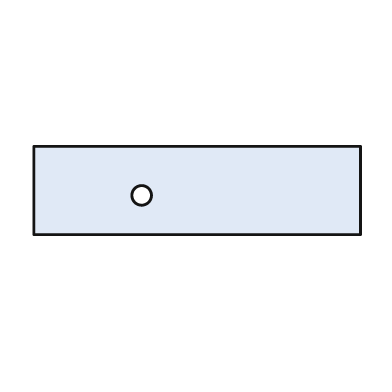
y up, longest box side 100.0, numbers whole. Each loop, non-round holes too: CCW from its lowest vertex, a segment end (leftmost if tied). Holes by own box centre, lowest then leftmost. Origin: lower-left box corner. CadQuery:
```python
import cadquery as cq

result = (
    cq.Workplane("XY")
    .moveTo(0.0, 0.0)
    .lineTo(100.0, 0.0)
    .lineTo(100.0, 27.0)
    .lineTo(0.0, 27.0)
    .close()
    .moveTo(33.0, 12.0)
    .circle(3.0)
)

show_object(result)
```